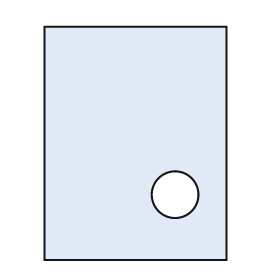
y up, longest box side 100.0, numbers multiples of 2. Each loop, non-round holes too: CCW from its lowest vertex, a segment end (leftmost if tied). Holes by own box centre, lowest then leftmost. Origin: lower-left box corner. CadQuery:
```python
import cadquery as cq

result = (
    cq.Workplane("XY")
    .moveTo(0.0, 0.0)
    .lineTo(78.0, 0.0)
    .lineTo(78.0, 100.0)
    .lineTo(0.0, 100.0)
    .close()
    .moveTo(56.0, 28.0)
    .circle(10.0)
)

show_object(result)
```